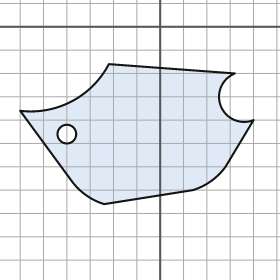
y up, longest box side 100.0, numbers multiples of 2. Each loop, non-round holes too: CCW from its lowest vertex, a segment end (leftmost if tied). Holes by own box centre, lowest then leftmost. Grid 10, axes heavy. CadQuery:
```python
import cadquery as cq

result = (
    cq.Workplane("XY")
    .moveTo(-24.0, -76.0)
    .lineTo(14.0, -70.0)
    .threePointArc((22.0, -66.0), (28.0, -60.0))
    .lineTo(40.0, -40.0)
    .threePointArc((26.0, -34.0), (32.0, -20.0))
    .lineTo(-22.0, -16.0)
    .threePointArc((-38.0, -32.0), (-60.0, -36.0))
    .lineTo(-38.0, -66.0)
    .threePointArc((-32.0, -72.0), (-24.0, -76.0))
    .close()
    .moveTo(-40.0, -46.0)
    .circle(4.0)
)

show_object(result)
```